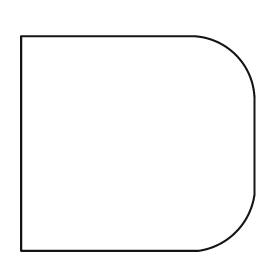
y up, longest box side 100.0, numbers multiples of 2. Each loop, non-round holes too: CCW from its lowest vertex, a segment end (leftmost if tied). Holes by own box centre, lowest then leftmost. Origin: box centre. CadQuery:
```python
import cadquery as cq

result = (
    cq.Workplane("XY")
    .moveTo(-50.0, -46.0)
    .lineTo(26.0, -46.0)
    .threePointArc((42.0, -38.0), (50.0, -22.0))
    .lineTo(50.0, 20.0)
    .threePointArc((42.0, 38.0), (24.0, 46.0))
    .lineTo(-50.0, 46.0)
    .close()
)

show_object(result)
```